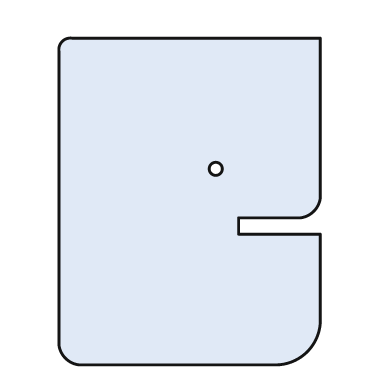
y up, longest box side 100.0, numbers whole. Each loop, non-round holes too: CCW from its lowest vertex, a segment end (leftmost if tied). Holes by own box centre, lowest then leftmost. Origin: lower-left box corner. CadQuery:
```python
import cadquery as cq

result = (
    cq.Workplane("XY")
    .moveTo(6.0, 0.0)
    .lineTo(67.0, 0.0)
    .threePointArc((76.0, 4.0), (80.0, 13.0))
    .lineTo(80.0, 40.0)
    .lineTo(55.0, 40.0)
    .lineTo(55.0, 45.0)
    .lineTo(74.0, 45.0)
    .threePointArc((78.0, 47.0), (80.0, 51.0))
    .lineTo(80.0, 100.0)
    .lineTo(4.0, 100.0)
    .threePointArc((1.0, 99.0), (0.0, 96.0))
    .lineTo(0.0, 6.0)
    .threePointArc((2.0, 2.0), (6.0, 0.0))
    .close()
    .moveTo(48.0, 60.0)
    .circle(2.0)
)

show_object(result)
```